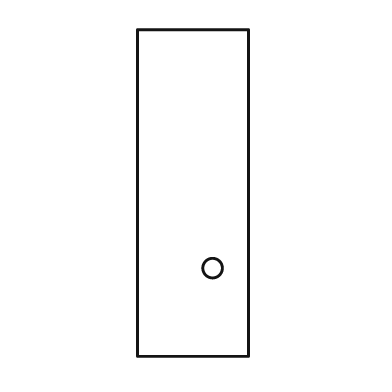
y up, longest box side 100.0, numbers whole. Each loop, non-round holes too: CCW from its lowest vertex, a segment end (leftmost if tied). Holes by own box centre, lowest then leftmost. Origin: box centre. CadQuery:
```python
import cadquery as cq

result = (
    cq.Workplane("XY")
    .moveTo(-17.0, -50.0)
    .lineTo(17.0, -50.0)
    .lineTo(17.0, 50.0)
    .lineTo(-17.0, 50.0)
    .close()
    .moveTo(6.0, -23.0)
    .circle(3.0)
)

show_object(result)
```